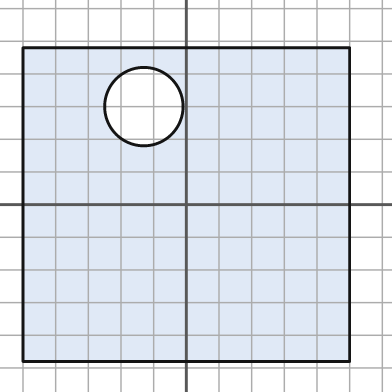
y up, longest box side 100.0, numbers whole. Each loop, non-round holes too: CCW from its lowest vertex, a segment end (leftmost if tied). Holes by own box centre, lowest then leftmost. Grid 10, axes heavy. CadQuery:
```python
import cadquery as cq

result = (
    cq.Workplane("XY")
    .moveTo(-50.0, -48.0)
    .lineTo(50.0, -48.0)
    .lineTo(50.0, 48.0)
    .lineTo(-50.0, 48.0)
    .close()
    .moveTo(-13.0, 30.0)
    .circle(12.0)
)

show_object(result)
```